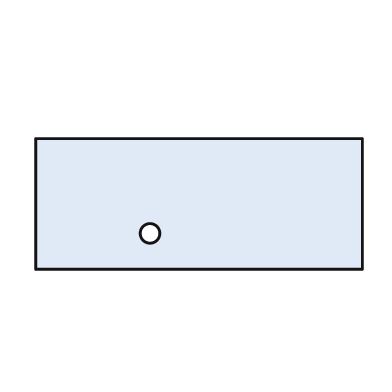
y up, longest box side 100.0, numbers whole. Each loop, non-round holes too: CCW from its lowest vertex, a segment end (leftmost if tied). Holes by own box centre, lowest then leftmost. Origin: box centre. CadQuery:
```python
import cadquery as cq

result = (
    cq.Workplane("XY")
    .moveTo(-50.0, -20.0)
    .lineTo(50.0, -20.0)
    .lineTo(50.0, 20.0)
    .lineTo(-50.0, 20.0)
    .close()
    .moveTo(-15.0, -9.0)
    .circle(3.0)
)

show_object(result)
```